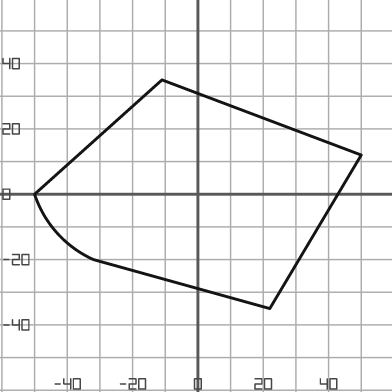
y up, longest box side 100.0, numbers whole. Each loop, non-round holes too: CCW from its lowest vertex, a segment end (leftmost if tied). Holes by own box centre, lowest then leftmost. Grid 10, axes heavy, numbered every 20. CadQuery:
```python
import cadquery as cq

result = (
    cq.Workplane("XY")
    .moveTo(22.0, -35.0)
    .lineTo(50.0, 12.0)
    .lineTo(-11.0, 35.0)
    .lineTo(-50.0, 0.0)
    .threePointArc((-43.0, -12.0), (-32.0, -20.0))
    .close()
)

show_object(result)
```